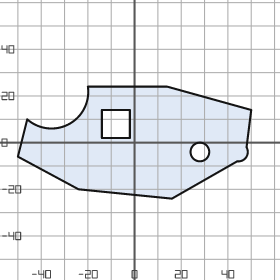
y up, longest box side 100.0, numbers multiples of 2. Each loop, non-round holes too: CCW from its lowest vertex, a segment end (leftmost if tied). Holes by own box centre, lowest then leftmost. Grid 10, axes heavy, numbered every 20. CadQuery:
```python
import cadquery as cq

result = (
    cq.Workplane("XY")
    .moveTo(16.0, -24.0)
    .lineTo(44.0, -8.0)
    .threePointArc((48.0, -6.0), (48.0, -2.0))
    .lineTo(50.0, 14.0)
    .lineTo(14.0, 24.0)
    .lineTo(-20.0, 24.0)
    .threePointArc((-28.0, 8.0), (-46.0, 10.0))
    .lineTo(-50.0, -6.0)
    .lineTo(-24.0, -20.0)
    .close()
    .moveTo(28.0, -4.0)
    .circle(4.0)
    .moveTo(-14.0, 2.0)
    .lineTo(-2.0, 2.0)
    .lineTo(-2.0, 14.0)
    .lineTo(-14.0, 14.0)
    .close()
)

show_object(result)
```